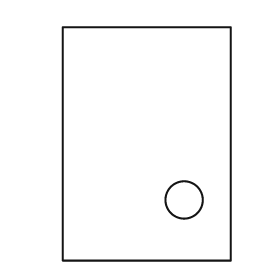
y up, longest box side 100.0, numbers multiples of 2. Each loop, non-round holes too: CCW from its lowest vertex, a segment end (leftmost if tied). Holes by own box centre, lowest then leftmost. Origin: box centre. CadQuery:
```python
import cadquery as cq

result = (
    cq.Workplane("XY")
    .moveTo(-36.0, -50.0)
    .lineTo(36.0, -50.0)
    .lineTo(36.0, 50.0)
    .lineTo(-36.0, 50.0)
    .close()
    .moveTo(16.0, -24.0)
    .circle(8.0)
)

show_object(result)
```